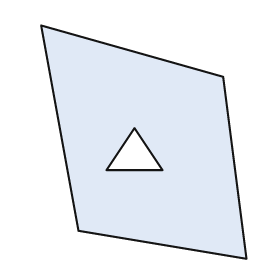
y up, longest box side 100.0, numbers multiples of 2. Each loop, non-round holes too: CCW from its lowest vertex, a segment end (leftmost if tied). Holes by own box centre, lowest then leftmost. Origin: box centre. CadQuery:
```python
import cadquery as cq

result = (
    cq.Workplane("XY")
    .moveTo(44.0, -50.0)
    .lineTo(34.0, 28.0)
    .lineTo(-44.0, 50.0)
    .lineTo(-28.0, -38.0)
    .close()
    .moveTo(-16.0, -12.0)
    .lineTo(8.0, -12.0)
    .lineTo(-4.0, 6.0)
    .close()
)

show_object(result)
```